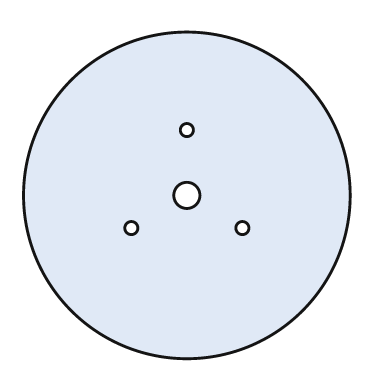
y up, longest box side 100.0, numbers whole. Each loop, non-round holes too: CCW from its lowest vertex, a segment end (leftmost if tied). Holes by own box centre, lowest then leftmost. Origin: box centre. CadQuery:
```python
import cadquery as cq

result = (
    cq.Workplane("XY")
    .moveTo(0.0, 0.0)
    .circle(50.0)
    .moveTo(-17.0, -10.0)
    .circle(2.0)
    .moveTo(17.0, -10.0)
    .circle(2.0)
    .moveTo(0.0, 0.0)
    .circle(4.0)
    .moveTo(0.0, 20.0)
    .circle(2.0)
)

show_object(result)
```